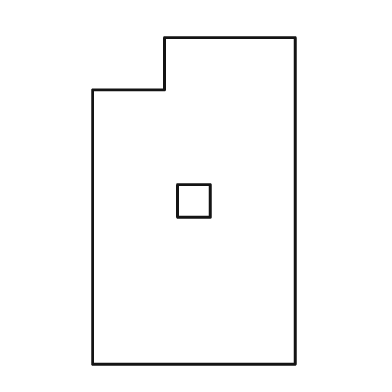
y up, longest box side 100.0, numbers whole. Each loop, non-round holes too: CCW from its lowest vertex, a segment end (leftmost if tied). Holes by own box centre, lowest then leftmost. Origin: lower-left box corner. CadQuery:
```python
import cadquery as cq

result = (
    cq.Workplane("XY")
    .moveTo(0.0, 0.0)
    .lineTo(62.0, 0.0)
    .lineTo(62.0, 100.0)
    .lineTo(22.0, 100.0)
    .lineTo(22.0, 84.0)
    .lineTo(0.0, 84.0)
    .close()
    .moveTo(26.0, 45.0)
    .lineTo(36.0, 45.0)
    .lineTo(36.0, 55.0)
    .lineTo(26.0, 55.0)
    .close()
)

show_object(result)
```